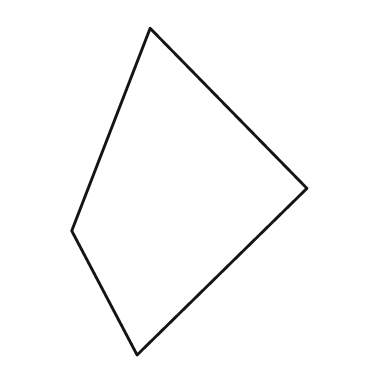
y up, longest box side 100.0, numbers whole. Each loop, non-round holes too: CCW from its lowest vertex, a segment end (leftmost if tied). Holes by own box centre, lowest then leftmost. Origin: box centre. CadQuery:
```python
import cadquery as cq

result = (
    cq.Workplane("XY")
    .moveTo(-16.0, -50.0)
    .lineTo(36.0, 1.0)
    .lineTo(-12.0, 50.0)
    .lineTo(-36.0, -12.0)
    .close()
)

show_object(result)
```